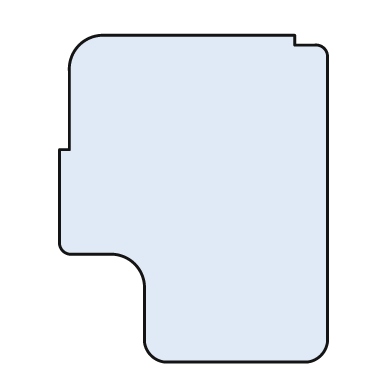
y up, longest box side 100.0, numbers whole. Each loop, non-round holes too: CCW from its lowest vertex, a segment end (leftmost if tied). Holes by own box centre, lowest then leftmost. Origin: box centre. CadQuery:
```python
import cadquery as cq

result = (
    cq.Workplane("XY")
    .moveTo(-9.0, -50.0)
    .lineTo(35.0, -50.0)
    .threePointArc((39.0, -48.0), (41.0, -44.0))
    .lineTo(41.0, 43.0)
    .threePointArc((40.0, 46.0), (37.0, 47.0))
    .lineTo(31.0, 47.0)
    .lineTo(31.0, 50.0)
    .lineTo(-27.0, 50.0)
    .threePointArc((-35.0, 47.0), (-38.0, 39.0))
    .lineTo(-38.0, 15.0)
    .lineTo(-41.0, 15.0)
    .lineTo(-41.0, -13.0)
    .threePointArc((-40.0, -16.0), (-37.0, -17.0))
    .lineTo(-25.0, -17.0)
    .threePointArc((-18.0, -20.0), (-15.0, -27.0))
    .lineTo(-15.0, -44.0)
    .threePointArc((-13.0, -48.0), (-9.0, -50.0))
    .close()
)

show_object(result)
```